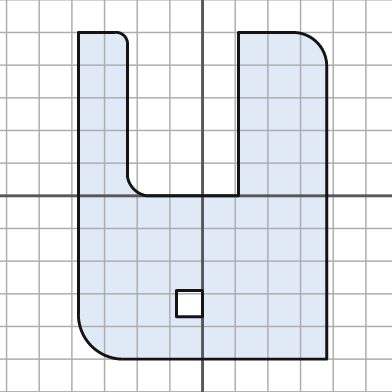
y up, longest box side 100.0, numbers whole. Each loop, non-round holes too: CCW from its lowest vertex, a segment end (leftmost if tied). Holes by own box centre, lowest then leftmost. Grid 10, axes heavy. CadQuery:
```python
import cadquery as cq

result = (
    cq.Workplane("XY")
    .moveTo(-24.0, -50.0)
    .lineTo(38.0, -50.0)
    .lineTo(38.0, 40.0)
    .threePointArc((35.0, 47.0), (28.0, 50.0))
    .lineTo(11.0, 50.0)
    .lineTo(11.0, 0.0)
    .lineTo(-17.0, 0.0)
    .threePointArc((-21.0, 2.0), (-23.0, 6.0))
    .lineTo(-23.0, 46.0)
    .threePointArc((-24.0, 49.0), (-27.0, 50.0))
    .lineTo(-38.0, 50.0)
    .lineTo(-38.0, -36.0)
    .threePointArc((-34.0, -46.0), (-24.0, -50.0))
    .close()
    .moveTo(-8.0, -37.0)
    .lineTo(0.0, -37.0)
    .lineTo(0.0, -29.0)
    .lineTo(-8.0, -29.0)
    .close()
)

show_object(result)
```